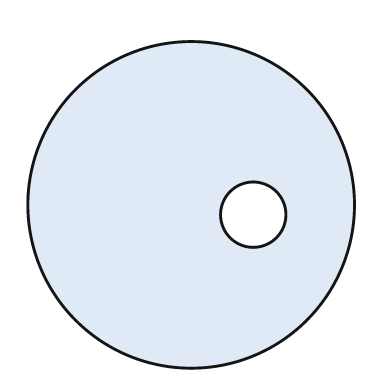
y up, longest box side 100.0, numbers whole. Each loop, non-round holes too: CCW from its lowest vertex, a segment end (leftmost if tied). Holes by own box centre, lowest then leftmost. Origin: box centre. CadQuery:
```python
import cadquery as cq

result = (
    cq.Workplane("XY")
    .moveTo(0.0, 0.0)
    .circle(50.0)
    .moveTo(19.0, -3.0)
    .circle(10.0)
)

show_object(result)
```